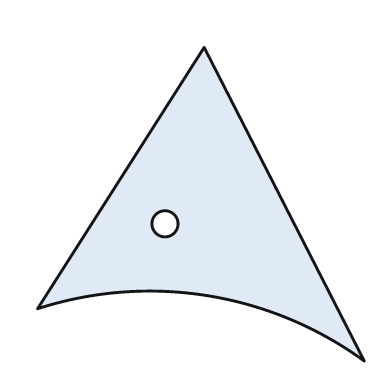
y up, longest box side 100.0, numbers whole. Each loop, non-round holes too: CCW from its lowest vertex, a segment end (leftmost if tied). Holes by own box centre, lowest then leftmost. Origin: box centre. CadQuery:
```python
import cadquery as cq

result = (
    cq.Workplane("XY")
    .moveTo(50.0, -48.0)
    .lineTo(1.0, 48.0)
    .lineTo(-50.0, -32.0)
    .threePointArc((2.0, -28.0), (50.0, -48.0))
    .close()
    .moveTo(-11.0, -6.0)
    .circle(4.0)
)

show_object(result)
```